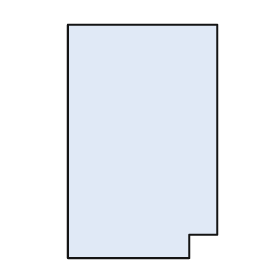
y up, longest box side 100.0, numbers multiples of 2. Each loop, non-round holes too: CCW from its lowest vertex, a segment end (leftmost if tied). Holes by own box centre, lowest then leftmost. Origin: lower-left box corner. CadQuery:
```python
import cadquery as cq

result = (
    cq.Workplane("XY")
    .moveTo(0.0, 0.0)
    .lineTo(52.0, 0.0)
    .lineTo(52.0, 10.0)
    .lineTo(64.0, 10.0)
    .lineTo(64.0, 100.0)
    .lineTo(0.0, 100.0)
    .close()
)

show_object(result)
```